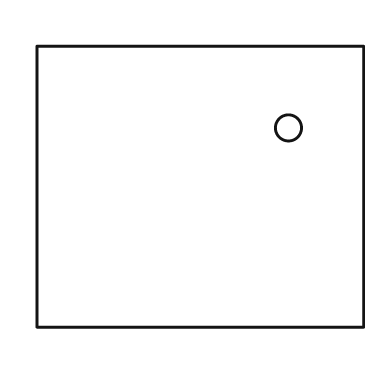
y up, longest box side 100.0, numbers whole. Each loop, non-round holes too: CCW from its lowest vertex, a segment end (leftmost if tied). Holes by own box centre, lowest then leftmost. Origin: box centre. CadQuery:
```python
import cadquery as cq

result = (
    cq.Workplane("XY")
    .moveTo(-50.0, -43.0)
    .lineTo(50.0, -43.0)
    .lineTo(50.0, 43.0)
    .lineTo(-50.0, 43.0)
    .close()
    .moveTo(27.0, 18.0)
    .circle(4.0)
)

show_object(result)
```